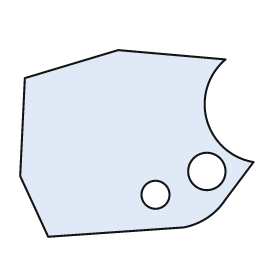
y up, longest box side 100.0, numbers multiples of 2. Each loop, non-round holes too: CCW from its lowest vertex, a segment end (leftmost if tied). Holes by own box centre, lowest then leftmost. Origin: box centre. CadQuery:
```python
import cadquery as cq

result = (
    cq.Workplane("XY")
    .moveTo(-38.0, -40.0)
    .lineTo(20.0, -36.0)
    .threePointArc((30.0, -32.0), (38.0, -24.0))
    .lineTo(50.0, -8.0)
    .threePointArc((30.0, 10.0), (38.0, 36.0))
    .lineTo(-8.0, 40.0)
    .lineTo(-48.0, 28.0)
    .lineTo(-50.0, -14.0)
    .close()
    .moveTo(8.0, -22.0)
    .circle(6.0)
    .moveTo(30.0, -12.0)
    .circle(8.0)
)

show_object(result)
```